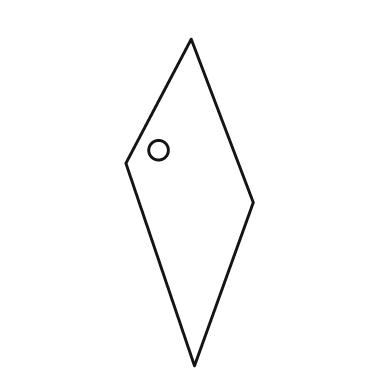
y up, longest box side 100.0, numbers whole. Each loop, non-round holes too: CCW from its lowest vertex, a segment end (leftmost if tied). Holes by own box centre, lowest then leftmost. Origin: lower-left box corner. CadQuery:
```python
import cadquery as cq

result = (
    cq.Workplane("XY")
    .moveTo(21.0, 0.0)
    .lineTo(39.0, 50.0)
    .lineTo(20.0, 100.0)
    .lineTo(0.0, 62.0)
    .close()
    .moveTo(10.0, 66.0)
    .circle(3.0)
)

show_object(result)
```